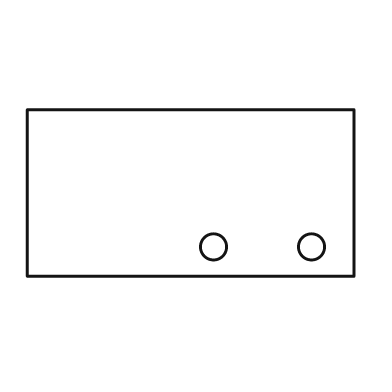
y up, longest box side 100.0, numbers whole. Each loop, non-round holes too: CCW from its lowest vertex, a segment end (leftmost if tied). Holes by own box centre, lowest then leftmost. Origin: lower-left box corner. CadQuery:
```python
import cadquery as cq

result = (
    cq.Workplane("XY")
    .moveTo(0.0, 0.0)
    .lineTo(100.0, 0.0)
    .lineTo(100.0, 51.0)
    .lineTo(0.0, 51.0)
    .close()
    .moveTo(57.0, 9.0)
    .circle(4.0)
    .moveTo(87.0, 9.0)
    .circle(4.0)
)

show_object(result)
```